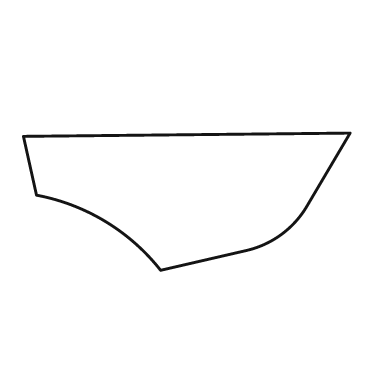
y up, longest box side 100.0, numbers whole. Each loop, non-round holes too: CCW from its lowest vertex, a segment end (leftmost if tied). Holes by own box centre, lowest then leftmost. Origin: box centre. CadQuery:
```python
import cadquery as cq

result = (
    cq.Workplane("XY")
    .moveTo(-8.0, -21.0)
    .lineTo(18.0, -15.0)
    .threePointArc((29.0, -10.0), (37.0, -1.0))
    .lineTo(50.0, 21.0)
    .lineTo(-50.0, 20.0)
    .lineTo(-46.0, 2.0)
    .threePointArc((-25.0, -6.0), (-8.0, -21.0))
    .close()
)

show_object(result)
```